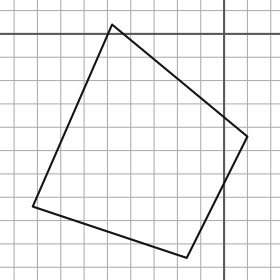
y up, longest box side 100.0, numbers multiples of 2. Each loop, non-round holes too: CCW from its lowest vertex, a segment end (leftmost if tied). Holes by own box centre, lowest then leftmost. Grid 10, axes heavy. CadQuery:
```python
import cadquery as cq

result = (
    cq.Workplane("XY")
    .moveTo(-16.0, -96.0)
    .lineTo(10.0, -44.0)
    .lineTo(-48.0, 4.0)
    .lineTo(-82.0, -74.0)
    .close()
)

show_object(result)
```